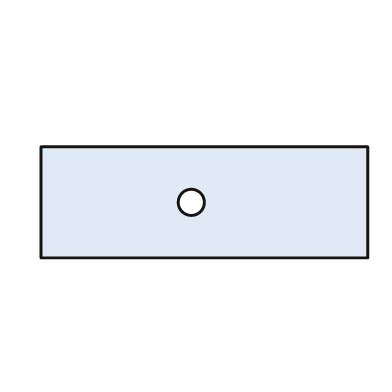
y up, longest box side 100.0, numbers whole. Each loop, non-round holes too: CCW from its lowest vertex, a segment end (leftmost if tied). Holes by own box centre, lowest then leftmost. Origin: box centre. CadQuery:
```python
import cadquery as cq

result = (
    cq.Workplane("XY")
    .moveTo(-50.0, -17.0)
    .lineTo(50.0, -17.0)
    .lineTo(50.0, 17.0)
    .lineTo(-50.0, 17.0)
    .close()
    .moveTo(-4.0, 0.0)
    .circle(4.0)
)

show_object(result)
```